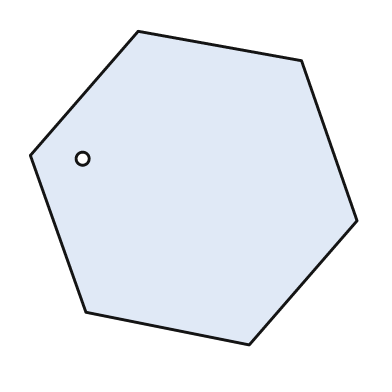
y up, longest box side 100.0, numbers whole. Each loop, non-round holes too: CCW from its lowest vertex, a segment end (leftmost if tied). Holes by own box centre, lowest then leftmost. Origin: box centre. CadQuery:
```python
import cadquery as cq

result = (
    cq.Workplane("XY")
    .moveTo(17.0, -48.0)
    .lineTo(50.0, -10.0)
    .lineTo(33.0, 39.0)
    .lineTo(-17.0, 48.0)
    .lineTo(-50.0, 10.0)
    .lineTo(-33.0, -38.0)
    .close()
    .moveTo(-34.0, 9.0)
    .circle(2.0)
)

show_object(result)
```